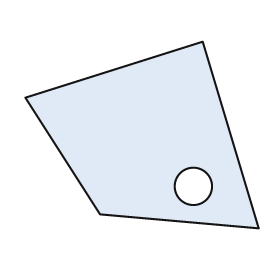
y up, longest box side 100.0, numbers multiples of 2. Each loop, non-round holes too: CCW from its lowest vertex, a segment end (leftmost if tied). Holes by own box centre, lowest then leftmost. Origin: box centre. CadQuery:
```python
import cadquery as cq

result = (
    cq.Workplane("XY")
    .moveTo(50.0, -40.0)
    .lineTo(26.0, 40.0)
    .lineTo(-50.0, 16.0)
    .lineTo(-18.0, -34.0)
    .close()
    .moveTo(22.0, -22.0)
    .circle(8.0)
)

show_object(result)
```